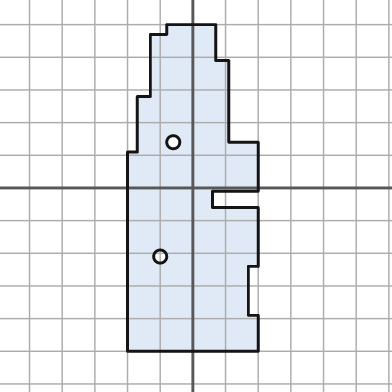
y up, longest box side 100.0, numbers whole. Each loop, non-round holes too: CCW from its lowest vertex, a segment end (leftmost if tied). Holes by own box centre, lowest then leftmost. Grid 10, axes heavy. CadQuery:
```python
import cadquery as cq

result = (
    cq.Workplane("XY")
    .moveTo(-20.0, -50.0)
    .lineTo(20.0, -50.0)
    .lineTo(20.0, -39.0)
    .lineTo(17.0, -39.0)
    .lineTo(17.0, -24.0)
    .lineTo(20.0, -24.0)
    .lineTo(20.0, -6.0)
    .lineTo(6.0, -6.0)
    .lineTo(6.0, -1.0)
    .lineTo(20.0, -1.0)
    .lineTo(20.0, 14.0)
    .lineTo(11.0, 14.0)
    .lineTo(11.0, 39.0)
    .lineTo(7.0, 39.0)
    .lineTo(7.0, 50.0)
    .lineTo(-8.0, 50.0)
    .lineTo(-8.0, 47.0)
    .lineTo(-13.0, 47.0)
    .lineTo(-13.0, 28.0)
    .lineTo(-17.0, 28.0)
    .lineTo(-17.0, 11.0)
    .lineTo(-20.0, 11.0)
    .close()
    .moveTo(-10.0, -21.0)
    .circle(2.0)
    .moveTo(-6.0, 14.0)
    .circle(2.0)
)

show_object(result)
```